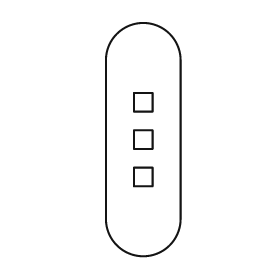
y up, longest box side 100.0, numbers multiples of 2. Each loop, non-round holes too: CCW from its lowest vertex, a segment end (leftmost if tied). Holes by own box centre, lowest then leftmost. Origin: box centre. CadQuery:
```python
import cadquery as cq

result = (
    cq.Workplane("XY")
    .moveTo(-16.0, -34.0)
    .threePointArc((0.0, -50.0), (16.0, -34.0))
    .lineTo(16.0, 34.0)
    .threePointArc((0.0, 50.0), (-16.0, 34.0))
    .close()
    .moveTo(-4.0, -20.0)
    .lineTo(4.0, -20.0)
    .lineTo(4.0, -12.0)
    .lineTo(-4.0, -12.0)
    .close()
    .moveTo(-4.0, -4.0)
    .lineTo(4.0, -4.0)
    .lineTo(4.0, 4.0)
    .lineTo(-4.0, 4.0)
    .close()
    .moveTo(-4.0, 12.0)
    .lineTo(4.0, 12.0)
    .lineTo(4.0, 20.0)
    .lineTo(-4.0, 20.0)
    .close()
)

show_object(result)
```